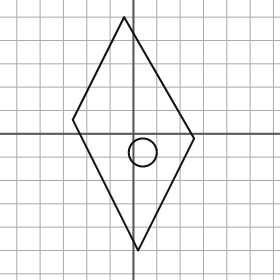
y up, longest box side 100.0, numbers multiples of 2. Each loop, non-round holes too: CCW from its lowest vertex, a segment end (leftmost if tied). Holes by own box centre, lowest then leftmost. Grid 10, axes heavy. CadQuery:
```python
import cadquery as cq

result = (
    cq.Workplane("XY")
    .moveTo(2.0, -50.0)
    .lineTo(26.0, -2.0)
    .lineTo(-4.0, 50.0)
    .lineTo(-26.0, 6.0)
    .close()
    .moveTo(4.0, -8.0)
    .circle(6.0)
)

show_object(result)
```